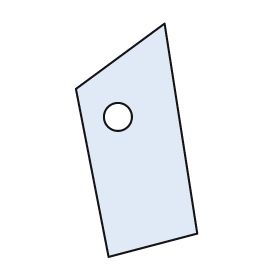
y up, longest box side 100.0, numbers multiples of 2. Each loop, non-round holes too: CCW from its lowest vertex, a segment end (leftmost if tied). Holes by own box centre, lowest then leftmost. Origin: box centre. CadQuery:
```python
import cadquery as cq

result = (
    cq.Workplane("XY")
    .moveTo(-12.0, -50.0)
    .lineTo(26.0, -40.0)
    .lineTo(12.0, 50.0)
    .lineTo(-26.0, 22.0)
    .close()
    .moveTo(-8.0, 10.0)
    .circle(6.0)
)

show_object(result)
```